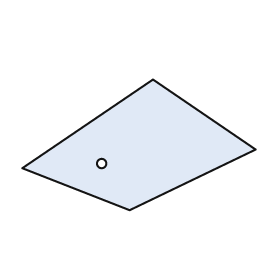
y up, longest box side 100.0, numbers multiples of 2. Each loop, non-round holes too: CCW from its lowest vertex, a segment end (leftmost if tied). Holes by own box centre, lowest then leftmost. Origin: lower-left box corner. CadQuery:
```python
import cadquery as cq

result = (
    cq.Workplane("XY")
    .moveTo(46.0, 0.0)
    .lineTo(100.0, 26.0)
    .lineTo(56.0, 56.0)
    .lineTo(0.0, 18.0)
    .close()
    .moveTo(34.0, 20.0)
    .circle(2.0)
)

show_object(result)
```